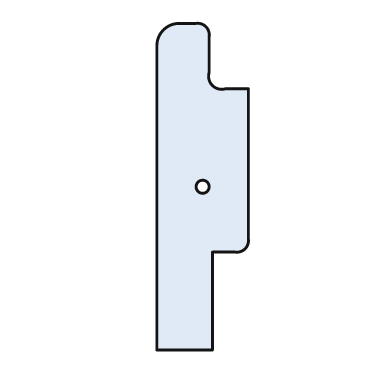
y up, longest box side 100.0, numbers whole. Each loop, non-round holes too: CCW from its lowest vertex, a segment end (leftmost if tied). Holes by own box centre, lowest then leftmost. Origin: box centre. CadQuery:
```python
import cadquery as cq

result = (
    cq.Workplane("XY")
    .moveTo(-14.0, -50.0)
    .lineTo(3.0, -50.0)
    .lineTo(3.0, -20.0)
    .lineTo(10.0, -20.0)
    .threePointArc((13.0, -19.0), (14.0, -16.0))
    .lineTo(14.0, 30.0)
    .lineTo(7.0, 30.0)
    .threePointArc((3.0, 31.0), (2.0, 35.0))
    .lineTo(2.0, 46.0)
    .threePointArc((1.0, 49.0), (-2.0, 50.0))
    .lineTo(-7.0, 50.0)
    .threePointArc((-12.0, 48.0), (-14.0, 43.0))
    .close()
    .moveTo(0.0, 0.0)
    .circle(2.0)
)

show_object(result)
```